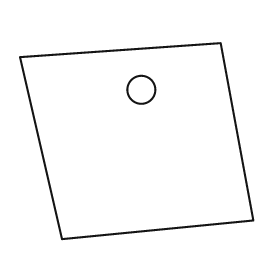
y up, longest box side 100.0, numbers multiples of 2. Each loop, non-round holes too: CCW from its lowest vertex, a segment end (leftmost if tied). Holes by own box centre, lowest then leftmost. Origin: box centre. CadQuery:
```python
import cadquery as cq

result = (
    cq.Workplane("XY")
    .moveTo(-32.0, -42.0)
    .lineTo(50.0, -34.0)
    .lineTo(36.0, 42.0)
    .lineTo(-50.0, 36.0)
    .close()
    .moveTo(2.0, 22.0)
    .circle(6.0)
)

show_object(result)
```